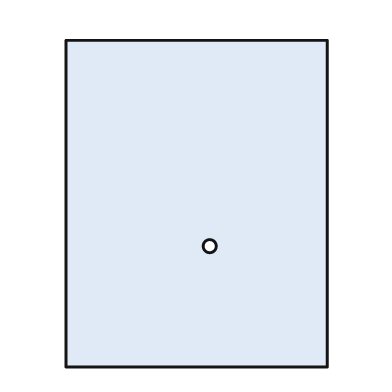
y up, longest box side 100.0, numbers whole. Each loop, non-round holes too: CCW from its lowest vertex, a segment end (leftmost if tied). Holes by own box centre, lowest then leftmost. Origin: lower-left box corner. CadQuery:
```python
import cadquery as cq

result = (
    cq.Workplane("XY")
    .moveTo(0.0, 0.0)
    .lineTo(80.0, 0.0)
    .lineTo(80.0, 100.0)
    .lineTo(0.0, 100.0)
    .close()
    .moveTo(44.0, 37.0)
    .circle(2.0)
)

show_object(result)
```